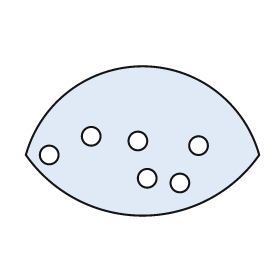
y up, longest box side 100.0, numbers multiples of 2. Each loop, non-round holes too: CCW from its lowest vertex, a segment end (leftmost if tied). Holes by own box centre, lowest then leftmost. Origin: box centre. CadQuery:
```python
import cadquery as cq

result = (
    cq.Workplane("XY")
    .moveTo(-50.0, -6.0)
    .threePointArc((0.0, -32.0), (50.0, -6.0))
    .threePointArc((0.0, 32.0), (-50.0, -6.0))
    .close()
    .moveTo(16.0, -18.0)
    .circle(4.0)
    .moveTo(2.0, -16.0)
    .circle(4.0)
    .moveTo(-40.0, -6.0)
    .circle(4.0)
    .moveTo(24.0, -2.0)
    .circle(4.0)
    .moveTo(-2.0, 0.0)
    .circle(4.0)
    .moveTo(-22.0, 2.0)
    .circle(4.0)
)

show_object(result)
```